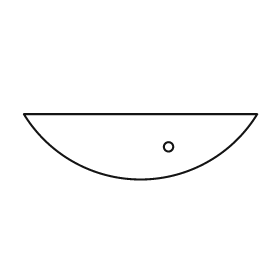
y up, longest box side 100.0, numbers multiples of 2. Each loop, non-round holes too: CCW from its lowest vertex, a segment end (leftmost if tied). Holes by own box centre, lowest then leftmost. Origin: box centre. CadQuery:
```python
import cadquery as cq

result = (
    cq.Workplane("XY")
    .moveTo(-50.0, 14.0)
    .threePointArc((0.0, -14.0), (50.0, 14.0))
    .close()
    .moveTo(12.0, 0.0)
    .circle(2.0)
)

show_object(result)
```